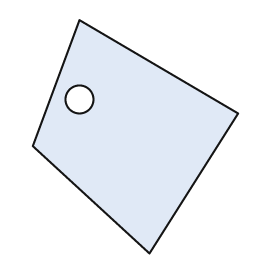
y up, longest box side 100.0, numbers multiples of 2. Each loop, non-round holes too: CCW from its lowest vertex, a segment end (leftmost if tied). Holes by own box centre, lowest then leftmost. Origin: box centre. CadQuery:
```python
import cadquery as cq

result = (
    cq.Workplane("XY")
    .moveTo(6.0, -50.0)
    .lineTo(44.0, 10.0)
    .lineTo(-24.0, 50.0)
    .lineTo(-44.0, -4.0)
    .close()
    .moveTo(-24.0, 16.0)
    .circle(6.0)
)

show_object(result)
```